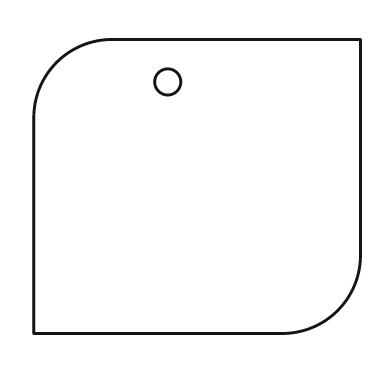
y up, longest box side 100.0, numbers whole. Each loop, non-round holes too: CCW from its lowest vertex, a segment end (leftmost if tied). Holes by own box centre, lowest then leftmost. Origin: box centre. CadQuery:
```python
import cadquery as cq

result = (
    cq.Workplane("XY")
    .moveTo(-50.0, -45.0)
    .lineTo(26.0, -45.0)
    .threePointArc((43.0, -38.0), (50.0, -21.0))
    .lineTo(50.0, 45.0)
    .lineTo(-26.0, 45.0)
    .threePointArc((-43.0, 38.0), (-50.0, 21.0))
    .close()
    .moveTo(-9.0, 32.0)
    .circle(4.0)
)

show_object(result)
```